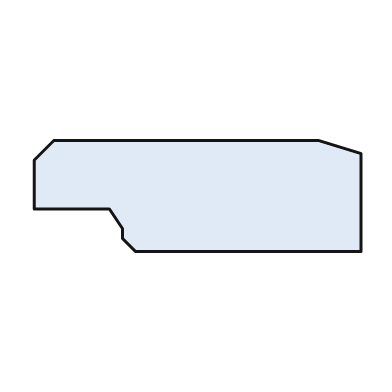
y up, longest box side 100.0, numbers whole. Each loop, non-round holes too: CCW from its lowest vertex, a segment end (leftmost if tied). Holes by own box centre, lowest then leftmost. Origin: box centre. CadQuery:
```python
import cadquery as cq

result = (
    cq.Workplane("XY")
    .moveTo(-19.0, -17.0)
    .lineTo(50.0, -17.0)
    .lineTo(50.0, 13.0)
    .lineTo(37.0, 17.0)
    .lineTo(-44.0, 17.0)
    .lineTo(-50.0, 11.0)
    .lineTo(-50.0, -4.0)
    .lineTo(-27.0, -4.0)
    .lineTo(-23.0, -10.0)
    .lineTo(-23.0, -13.0)
    .close()
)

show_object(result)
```